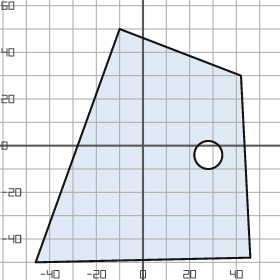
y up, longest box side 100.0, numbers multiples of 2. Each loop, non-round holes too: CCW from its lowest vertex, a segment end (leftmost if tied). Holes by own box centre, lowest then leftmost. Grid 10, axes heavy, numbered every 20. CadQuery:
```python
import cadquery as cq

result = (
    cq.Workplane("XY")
    .moveTo(-46.0, -50.0)
    .lineTo(46.0, -48.0)
    .lineTo(42.0, 30.0)
    .lineTo(-10.0, 50.0)
    .close()
    .moveTo(28.0, -4.0)
    .circle(6.0)
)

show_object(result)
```